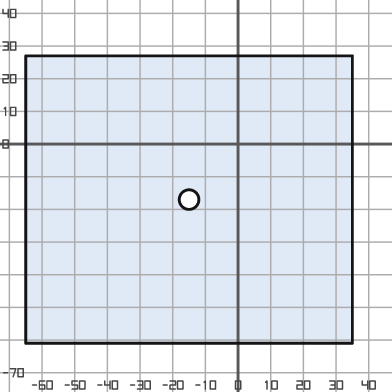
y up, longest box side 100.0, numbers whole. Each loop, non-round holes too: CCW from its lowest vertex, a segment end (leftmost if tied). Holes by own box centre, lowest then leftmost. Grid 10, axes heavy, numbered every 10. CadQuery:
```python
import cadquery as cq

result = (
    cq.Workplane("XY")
    .moveTo(-65.0, -61.0)
    .lineTo(35.0, -61.0)
    .lineTo(35.0, 27.0)
    .lineTo(-65.0, 27.0)
    .close()
    .moveTo(-15.0, -17.0)
    .circle(3.0)
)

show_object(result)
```